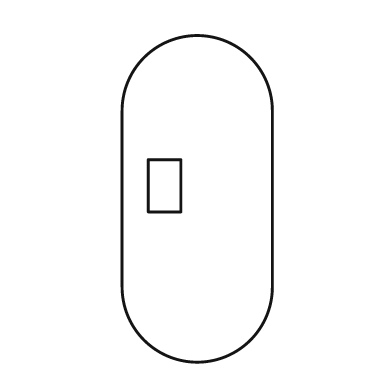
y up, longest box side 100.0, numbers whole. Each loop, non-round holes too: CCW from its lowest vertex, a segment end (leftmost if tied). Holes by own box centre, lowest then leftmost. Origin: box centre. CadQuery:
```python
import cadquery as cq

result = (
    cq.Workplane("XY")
    .moveTo(-23.0, -27.0)
    .threePointArc((0.0, -50.0), (23.0, -27.0))
    .lineTo(23.0, 27.0)
    .threePointArc((0.0, 50.0), (-23.0, 27.0))
    .close()
    .moveTo(-15.0, -4.0)
    .lineTo(-5.0, -4.0)
    .lineTo(-5.0, 12.0)
    .lineTo(-15.0, 12.0)
    .close()
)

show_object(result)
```